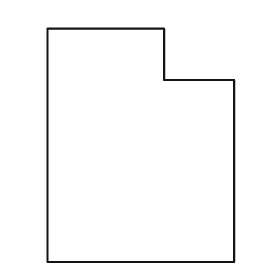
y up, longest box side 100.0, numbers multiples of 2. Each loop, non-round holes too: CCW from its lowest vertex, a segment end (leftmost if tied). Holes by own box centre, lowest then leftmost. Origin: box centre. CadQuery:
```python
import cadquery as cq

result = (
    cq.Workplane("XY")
    .moveTo(-40.0, -50.0)
    .lineTo(40.0, -50.0)
    .lineTo(40.0, 28.0)
    .lineTo(10.0, 28.0)
    .lineTo(10.0, 50.0)
    .lineTo(-40.0, 50.0)
    .close()
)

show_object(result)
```